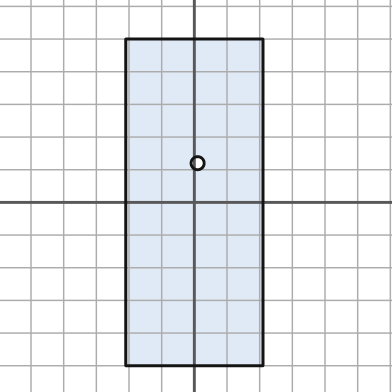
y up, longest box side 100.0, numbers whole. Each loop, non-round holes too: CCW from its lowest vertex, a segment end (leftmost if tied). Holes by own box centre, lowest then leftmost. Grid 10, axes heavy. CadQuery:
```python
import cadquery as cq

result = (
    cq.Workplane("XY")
    .moveTo(-21.0, -50.0)
    .lineTo(21.0, -50.0)
    .lineTo(21.0, 50.0)
    .lineTo(-21.0, 50.0)
    .close()
    .moveTo(1.0, 12.0)
    .circle(2.0)
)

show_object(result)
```